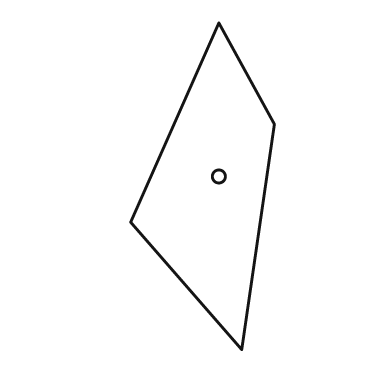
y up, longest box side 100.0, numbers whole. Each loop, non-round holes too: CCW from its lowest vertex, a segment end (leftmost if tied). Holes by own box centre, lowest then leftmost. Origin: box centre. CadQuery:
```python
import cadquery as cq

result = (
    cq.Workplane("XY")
    .moveTo(12.0, -50.0)
    .lineTo(22.0, 19.0)
    .lineTo(5.0, 50.0)
    .lineTo(-22.0, -11.0)
    .close()
    .moveTo(5.0, 3.0)
    .circle(2.0)
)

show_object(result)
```